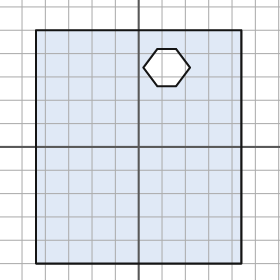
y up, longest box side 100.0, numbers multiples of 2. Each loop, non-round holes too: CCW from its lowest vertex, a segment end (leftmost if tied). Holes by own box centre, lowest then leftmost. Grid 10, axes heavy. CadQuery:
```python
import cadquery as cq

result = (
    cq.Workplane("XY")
    .moveTo(-44.0, -50.0)
    .lineTo(44.0, -50.0)
    .lineTo(44.0, 50.0)
    .lineTo(-44.0, 50.0)
    .close()
    .moveTo(8.0, 26.0)
    .lineTo(16.0, 26.0)
    .lineTo(22.0, 34.0)
    .lineTo(16.0, 42.0)
    .lineTo(8.0, 42.0)
    .lineTo(2.0, 34.0)
    .close()
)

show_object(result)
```